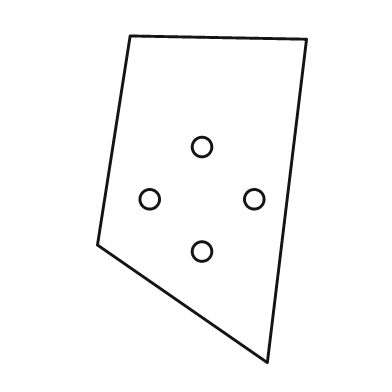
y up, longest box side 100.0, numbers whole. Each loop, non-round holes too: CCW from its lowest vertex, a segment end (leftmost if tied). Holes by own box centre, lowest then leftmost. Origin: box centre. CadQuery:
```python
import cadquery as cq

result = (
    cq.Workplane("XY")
    .moveTo(20.0, -50.0)
    .lineTo(32.0, 49.0)
    .lineTo(-22.0, 50.0)
    .lineTo(-32.0, -14.0)
    .close()
    .moveTo(0.0, -16.0)
    .circle(3.0)
    .moveTo(-16.0, 0.0)
    .circle(3.0)
    .moveTo(16.0, 0.0)
    .circle(3.0)
    .moveTo(0.0, 16.0)
    .circle(3.0)
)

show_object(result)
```